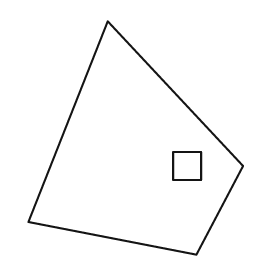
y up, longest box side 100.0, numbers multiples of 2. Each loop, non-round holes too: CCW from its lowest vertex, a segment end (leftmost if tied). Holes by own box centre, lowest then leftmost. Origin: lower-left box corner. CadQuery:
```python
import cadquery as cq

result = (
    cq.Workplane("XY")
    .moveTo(72.0, 0.0)
    .lineTo(92.0, 38.0)
    .lineTo(34.0, 100.0)
    .lineTo(0.0, 14.0)
    .close()
    .moveTo(62.0, 32.0)
    .lineTo(74.0, 32.0)
    .lineTo(74.0, 44.0)
    .lineTo(62.0, 44.0)
    .close()
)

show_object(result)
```